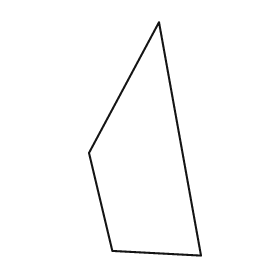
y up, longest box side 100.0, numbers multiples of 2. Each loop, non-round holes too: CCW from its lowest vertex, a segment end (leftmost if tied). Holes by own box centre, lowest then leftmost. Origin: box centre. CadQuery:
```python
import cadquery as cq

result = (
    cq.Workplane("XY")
    .moveTo(24.0, -50.0)
    .lineTo(6.0, 50.0)
    .lineTo(-24.0, -6.0)
    .lineTo(-14.0, -48.0)
    .close()
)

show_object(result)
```